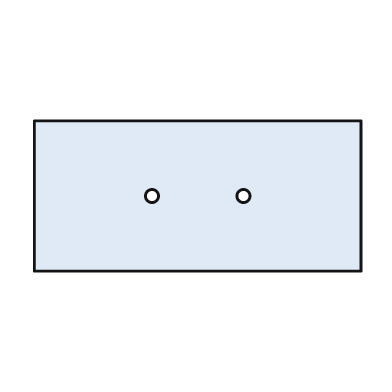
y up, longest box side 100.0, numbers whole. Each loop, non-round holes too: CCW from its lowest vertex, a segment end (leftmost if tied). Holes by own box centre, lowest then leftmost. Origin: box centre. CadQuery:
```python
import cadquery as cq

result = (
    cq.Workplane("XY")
    .moveTo(-50.0, -23.0)
    .lineTo(50.0, -23.0)
    .lineTo(50.0, 23.0)
    .lineTo(-50.0, 23.0)
    .close()
    .moveTo(-14.0, 0.0)
    .circle(2.0)
    .moveTo(14.0, 0.0)
    .circle(2.0)
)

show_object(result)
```